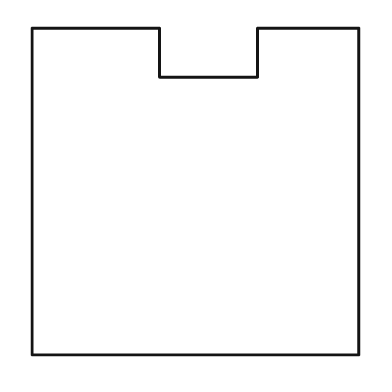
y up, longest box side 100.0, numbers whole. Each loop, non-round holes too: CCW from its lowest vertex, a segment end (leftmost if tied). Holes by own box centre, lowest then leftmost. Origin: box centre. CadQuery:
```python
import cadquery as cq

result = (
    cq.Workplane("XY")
    .moveTo(-50.0, -50.0)
    .lineTo(50.0, -50.0)
    .lineTo(50.0, 50.0)
    .lineTo(19.0, 50.0)
    .lineTo(19.0, 35.0)
    .lineTo(-11.0, 35.0)
    .lineTo(-11.0, 50.0)
    .lineTo(-50.0, 50.0)
    .close()
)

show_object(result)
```